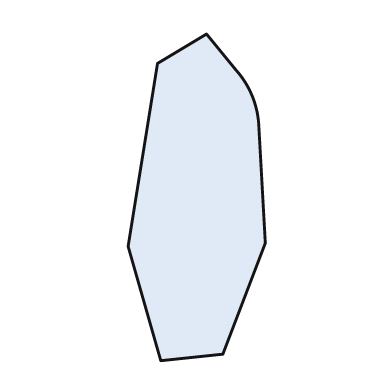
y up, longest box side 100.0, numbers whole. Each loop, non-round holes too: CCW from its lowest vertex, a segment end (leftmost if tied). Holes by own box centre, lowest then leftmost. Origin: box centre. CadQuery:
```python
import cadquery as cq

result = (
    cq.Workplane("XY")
    .moveTo(-11.0, -50.0)
    .lineTo(8.0, -48.0)
    .lineTo(21.0, -14.0)
    .lineTo(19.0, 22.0)
    .threePointArc((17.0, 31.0), (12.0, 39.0))
    .lineTo(3.0, 50.0)
    .lineTo(-12.0, 41.0)
    .lineTo(-21.0, -15.0)
    .close()
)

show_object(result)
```